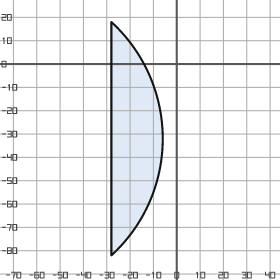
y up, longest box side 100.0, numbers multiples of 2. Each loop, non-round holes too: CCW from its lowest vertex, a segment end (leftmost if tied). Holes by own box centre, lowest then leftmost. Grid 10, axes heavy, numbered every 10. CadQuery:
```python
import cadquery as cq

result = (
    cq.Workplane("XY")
    .moveTo(-28.0, -82.0)
    .threePointArc((-6.0, -32.0), (-28.0, 18.0))
    .close()
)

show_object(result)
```